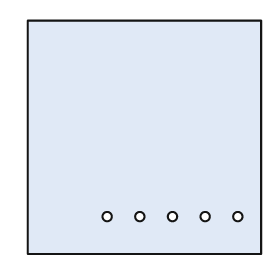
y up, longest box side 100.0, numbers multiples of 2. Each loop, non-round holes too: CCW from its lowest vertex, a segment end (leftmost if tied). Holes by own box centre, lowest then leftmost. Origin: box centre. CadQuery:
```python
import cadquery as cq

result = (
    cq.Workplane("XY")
    .moveTo(-50.0, -50.0)
    .lineTo(50.0, -50.0)
    .lineTo(50.0, 50.0)
    .lineTo(-50.0, 50.0)
    .close()
    .moveTo(-16.0, -34.0)
    .circle(2.0)
    .moveTo(-2.0, -34.0)
    .circle(2.0)
    .moveTo(12.0, -34.0)
    .circle(2.0)
    .moveTo(26.0, -34.0)
    .circle(2.0)
    .moveTo(40.0, -34.0)
    .circle(2.0)
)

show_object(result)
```